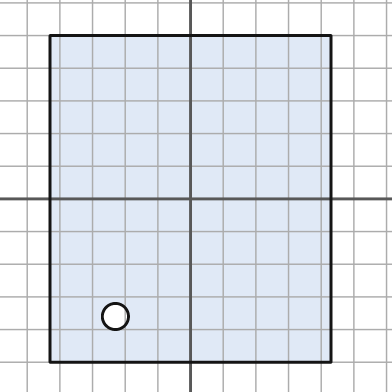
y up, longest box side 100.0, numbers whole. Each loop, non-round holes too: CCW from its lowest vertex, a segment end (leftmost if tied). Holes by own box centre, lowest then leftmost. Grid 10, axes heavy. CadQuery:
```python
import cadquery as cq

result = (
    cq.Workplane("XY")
    .moveTo(-43.0, -50.0)
    .lineTo(43.0, -50.0)
    .lineTo(43.0, 50.0)
    .lineTo(-43.0, 50.0)
    .close()
    .moveTo(-23.0, -36.0)
    .circle(4.0)
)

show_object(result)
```